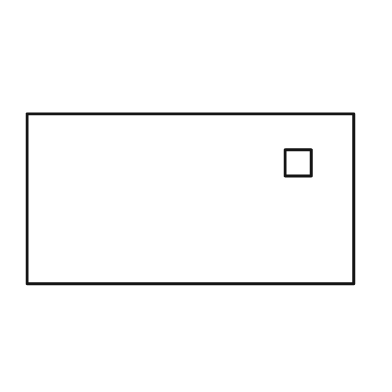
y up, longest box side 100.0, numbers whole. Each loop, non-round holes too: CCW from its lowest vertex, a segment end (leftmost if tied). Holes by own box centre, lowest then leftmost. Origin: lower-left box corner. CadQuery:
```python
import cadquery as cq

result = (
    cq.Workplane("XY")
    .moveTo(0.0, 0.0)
    .lineTo(100.0, 0.0)
    .lineTo(100.0, 52.0)
    .lineTo(0.0, 52.0)
    .close()
    .moveTo(79.0, 33.0)
    .lineTo(87.0, 33.0)
    .lineTo(87.0, 41.0)
    .lineTo(79.0, 41.0)
    .close()
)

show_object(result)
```